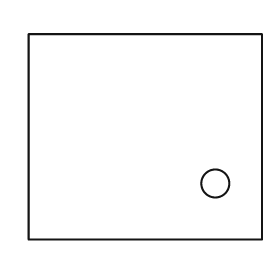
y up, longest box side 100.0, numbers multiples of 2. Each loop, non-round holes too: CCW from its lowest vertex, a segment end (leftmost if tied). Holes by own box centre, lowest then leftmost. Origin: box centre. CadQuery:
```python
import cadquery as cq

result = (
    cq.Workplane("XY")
    .moveTo(-50.0, -44.0)
    .lineTo(50.0, -44.0)
    .lineTo(50.0, 44.0)
    .lineTo(-50.0, 44.0)
    .close()
    .moveTo(30.0, -20.0)
    .circle(6.0)
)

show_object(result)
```